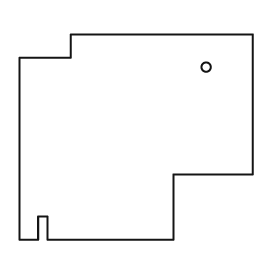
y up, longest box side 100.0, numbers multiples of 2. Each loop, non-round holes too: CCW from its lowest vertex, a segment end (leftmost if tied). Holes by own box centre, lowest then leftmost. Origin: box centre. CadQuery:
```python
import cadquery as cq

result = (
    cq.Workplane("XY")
    .moveTo(-50.0, -44.0)
    .lineTo(-42.0, -44.0)
    .lineTo(-42.0, -34.0)
    .lineTo(-38.0, -34.0)
    .lineTo(-38.0, -44.0)
    .lineTo(16.0, -44.0)
    .lineTo(16.0, -16.0)
    .lineTo(50.0, -16.0)
    .lineTo(50.0, 44.0)
    .lineTo(-28.0, 44.0)
    .lineTo(-28.0, 34.0)
    .lineTo(-50.0, 34.0)
    .close()
    .moveTo(30.0, 30.0)
    .circle(2.0)
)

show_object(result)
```